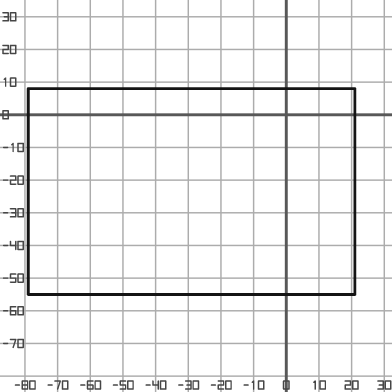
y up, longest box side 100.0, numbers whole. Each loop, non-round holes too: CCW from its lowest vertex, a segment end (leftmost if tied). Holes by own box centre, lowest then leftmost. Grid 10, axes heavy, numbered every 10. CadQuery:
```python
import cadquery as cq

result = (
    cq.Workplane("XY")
    .moveTo(-79.0, -55.0)
    .lineTo(21.0, -55.0)
    .lineTo(21.0, 8.0)
    .lineTo(-79.0, 8.0)
    .close()
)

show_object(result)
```